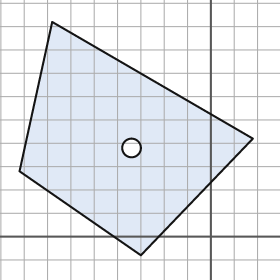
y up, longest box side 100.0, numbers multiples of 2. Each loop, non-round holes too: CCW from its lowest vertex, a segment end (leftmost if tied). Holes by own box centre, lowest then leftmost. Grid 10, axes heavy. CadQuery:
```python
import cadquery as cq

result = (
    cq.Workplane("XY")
    .moveTo(-30.0, -8.0)
    .lineTo(18.0, 42.0)
    .lineTo(-68.0, 92.0)
    .lineTo(-82.0, 28.0)
    .close()
    .moveTo(-34.0, 38.0)
    .circle(4.0)
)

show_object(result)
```